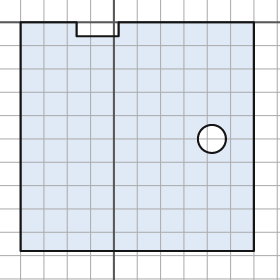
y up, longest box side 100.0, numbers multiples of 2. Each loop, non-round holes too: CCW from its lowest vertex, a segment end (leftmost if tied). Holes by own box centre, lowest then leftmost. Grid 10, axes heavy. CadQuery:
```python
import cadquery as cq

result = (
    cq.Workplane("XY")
    .moveTo(-40.0, -98.0)
    .lineTo(60.0, -98.0)
    .lineTo(60.0, 0.0)
    .lineTo(2.0, 0.0)
    .lineTo(2.0, -6.0)
    .lineTo(-16.0, -6.0)
    .lineTo(-16.0, 0.0)
    .lineTo(-40.0, 0.0)
    .close()
    .moveTo(42.0, -50.0)
    .circle(6.0)
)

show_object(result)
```